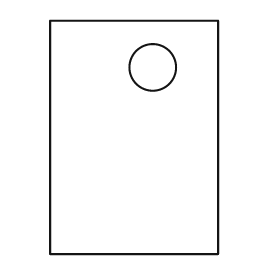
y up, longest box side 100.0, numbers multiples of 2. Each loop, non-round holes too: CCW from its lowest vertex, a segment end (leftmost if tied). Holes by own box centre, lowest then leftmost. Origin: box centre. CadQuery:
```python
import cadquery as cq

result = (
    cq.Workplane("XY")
    .moveTo(-36.0, -50.0)
    .lineTo(36.0, -50.0)
    .lineTo(36.0, 50.0)
    .lineTo(-36.0, 50.0)
    .close()
    .moveTo(8.0, 30.0)
    .circle(10.0)
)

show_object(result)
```